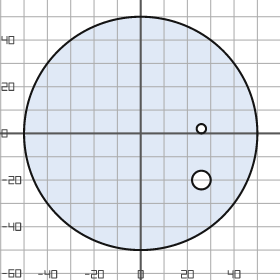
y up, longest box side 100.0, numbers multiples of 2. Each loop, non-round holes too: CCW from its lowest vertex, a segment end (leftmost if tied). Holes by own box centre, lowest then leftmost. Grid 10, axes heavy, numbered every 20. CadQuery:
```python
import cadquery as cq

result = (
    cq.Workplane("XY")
    .moveTo(0.0, 0.0)
    .circle(50.0)
    .moveTo(26.0, -20.0)
    .circle(4.0)
    .moveTo(26.0, 2.0)
    .circle(2.0)
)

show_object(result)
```